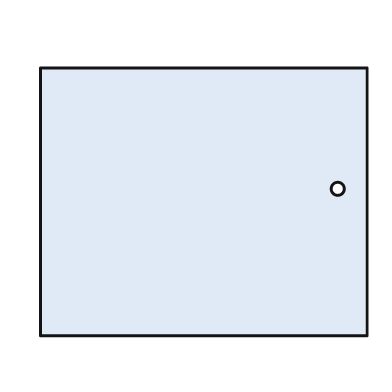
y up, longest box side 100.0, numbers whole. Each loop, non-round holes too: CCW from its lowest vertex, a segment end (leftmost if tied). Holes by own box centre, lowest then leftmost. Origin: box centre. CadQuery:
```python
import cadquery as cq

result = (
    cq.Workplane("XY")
    .moveTo(-50.0, -41.0)
    .lineTo(50.0, -41.0)
    .lineTo(50.0, 41.0)
    .lineTo(-50.0, 41.0)
    .close()
    .moveTo(41.0, 4.0)
    .circle(2.0)
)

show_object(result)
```